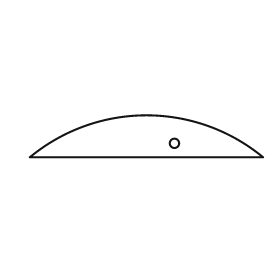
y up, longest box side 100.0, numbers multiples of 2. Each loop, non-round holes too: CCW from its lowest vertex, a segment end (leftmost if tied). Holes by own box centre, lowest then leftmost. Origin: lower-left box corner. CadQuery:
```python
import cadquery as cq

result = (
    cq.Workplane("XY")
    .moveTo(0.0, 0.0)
    .lineTo(100.0, 0.0)
    .threePointArc((50.0, 18.0), (0.0, 0.0))
    .close()
    .moveTo(62.0, 6.0)
    .circle(2.0)
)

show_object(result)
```